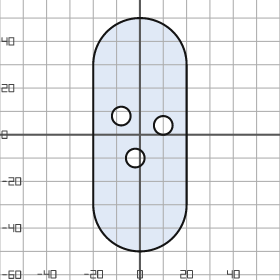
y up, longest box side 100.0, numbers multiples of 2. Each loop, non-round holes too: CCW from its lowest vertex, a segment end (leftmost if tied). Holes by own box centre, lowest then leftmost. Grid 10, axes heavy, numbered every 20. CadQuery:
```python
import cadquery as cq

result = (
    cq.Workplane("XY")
    .moveTo(-20.0, -30.0)
    .threePointArc((0.0, -50.0), (20.0, -30.0))
    .lineTo(20.0, 30.0)
    .threePointArc((0.0, 50.0), (-20.0, 30.0))
    .close()
    .moveTo(-2.0, -10.0)
    .circle(4.0)
    .moveTo(10.0, 4.0)
    .circle(4.0)
    .moveTo(-8.0, 8.0)
    .circle(4.0)
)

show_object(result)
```